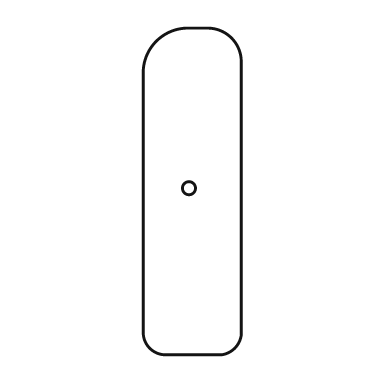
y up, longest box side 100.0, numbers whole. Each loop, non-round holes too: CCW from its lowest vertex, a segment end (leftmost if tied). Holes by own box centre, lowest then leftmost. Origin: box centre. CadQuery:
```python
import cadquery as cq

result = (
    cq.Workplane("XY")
    .moveTo(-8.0, -50.0)
    .lineTo(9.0, -50.0)
    .threePointArc((13.0, -48.0), (15.0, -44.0))
    .lineTo(15.0, 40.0)
    .threePointArc((12.0, 47.0), (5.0, 50.0))
    .lineTo(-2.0, 50.0)
    .threePointArc((-11.0, 46.0), (-15.0, 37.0))
    .lineTo(-15.0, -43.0)
    .threePointArc((-13.0, -48.0), (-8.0, -50.0))
    .close()
    .moveTo(-1.0, 1.0)
    .circle(2.0)
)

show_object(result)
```